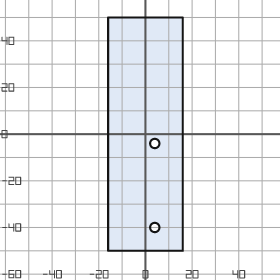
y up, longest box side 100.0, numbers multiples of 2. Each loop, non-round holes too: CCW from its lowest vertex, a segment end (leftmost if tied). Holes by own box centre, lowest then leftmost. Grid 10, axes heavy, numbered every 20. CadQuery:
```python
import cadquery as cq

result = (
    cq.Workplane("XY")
    .moveTo(-16.0, -50.0)
    .lineTo(16.0, -50.0)
    .lineTo(16.0, 50.0)
    .lineTo(-16.0, 50.0)
    .close()
    .moveTo(4.0, -40.0)
    .circle(2.0)
    .moveTo(4.0, -4.0)
    .circle(2.0)
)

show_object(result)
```